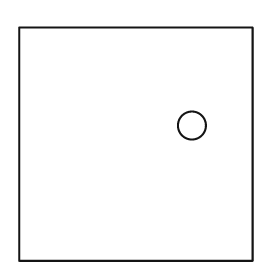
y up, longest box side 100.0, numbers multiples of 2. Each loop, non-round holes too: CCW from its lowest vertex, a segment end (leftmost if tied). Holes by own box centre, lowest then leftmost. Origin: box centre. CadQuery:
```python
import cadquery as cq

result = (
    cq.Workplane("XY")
    .moveTo(-50.0, -50.0)
    .lineTo(50.0, -50.0)
    .lineTo(50.0, 50.0)
    .lineTo(-50.0, 50.0)
    .close()
    .moveTo(24.0, 8.0)
    .circle(6.0)
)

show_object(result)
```